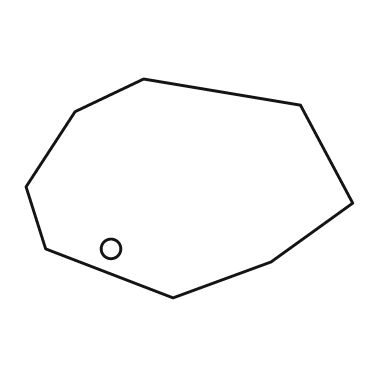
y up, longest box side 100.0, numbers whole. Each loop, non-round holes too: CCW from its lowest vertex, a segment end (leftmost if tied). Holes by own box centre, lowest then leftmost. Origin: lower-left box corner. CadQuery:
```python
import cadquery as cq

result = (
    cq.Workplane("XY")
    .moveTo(45.0, 0.0)
    .lineTo(75.0, 11.0)
    .lineTo(100.0, 29.0)
    .lineTo(84.0, 59.0)
    .lineTo(36.0, 67.0)
    .lineTo(15.0, 57.0)
    .lineTo(0.0, 34.0)
    .lineTo(6.0, 15.0)
    .close()
    .moveTo(26.0, 15.0)
    .circle(3.0)
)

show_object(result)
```